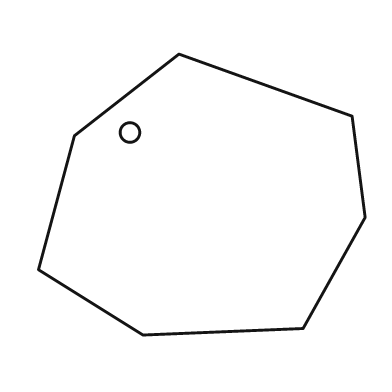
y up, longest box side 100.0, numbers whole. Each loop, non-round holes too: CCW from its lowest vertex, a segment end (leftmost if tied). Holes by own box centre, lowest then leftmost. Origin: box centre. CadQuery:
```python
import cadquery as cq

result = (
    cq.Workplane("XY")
    .moveTo(-18.0, -43.0)
    .lineTo(31.0, -41.0)
    .lineTo(50.0, -7.0)
    .lineTo(46.0, 24.0)
    .lineTo(-7.0, 43.0)
    .lineTo(-39.0, 18.0)
    .lineTo(-50.0, -23.0)
    .close()
    .moveTo(-22.0, 19.0)
    .circle(3.0)
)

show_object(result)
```